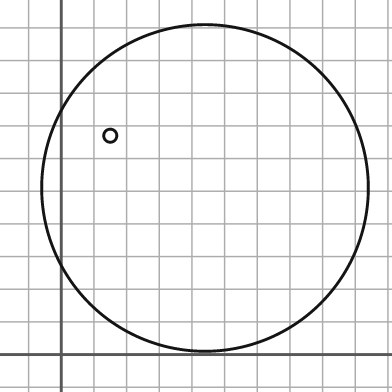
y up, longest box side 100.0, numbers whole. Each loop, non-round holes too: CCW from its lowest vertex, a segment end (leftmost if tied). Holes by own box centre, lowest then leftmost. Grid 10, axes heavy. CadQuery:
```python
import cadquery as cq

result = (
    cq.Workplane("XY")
    .moveTo(44.0, 51.0)
    .circle(50.0)
    .moveTo(15.0, 67.0)
    .circle(2.0)
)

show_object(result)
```